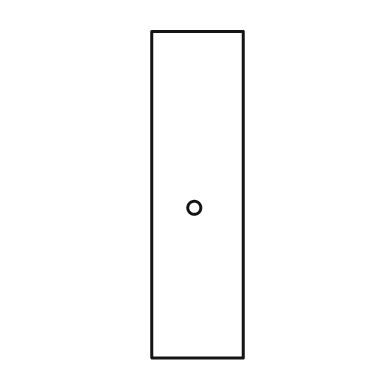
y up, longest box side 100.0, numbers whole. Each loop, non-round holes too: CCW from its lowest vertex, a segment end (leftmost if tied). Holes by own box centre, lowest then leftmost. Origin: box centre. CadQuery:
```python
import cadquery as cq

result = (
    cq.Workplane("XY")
    .moveTo(-14.0, -50.0)
    .lineTo(14.0, -50.0)
    .lineTo(14.0, 50.0)
    .lineTo(-14.0, 50.0)
    .close()
    .moveTo(-1.0, -4.0)
    .circle(2.0)
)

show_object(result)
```